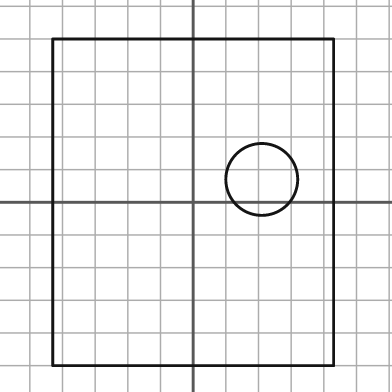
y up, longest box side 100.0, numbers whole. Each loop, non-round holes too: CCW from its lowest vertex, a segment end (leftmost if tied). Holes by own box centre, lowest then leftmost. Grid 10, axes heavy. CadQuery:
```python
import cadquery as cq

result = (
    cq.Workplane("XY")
    .moveTo(-43.0, -50.0)
    .lineTo(43.0, -50.0)
    .lineTo(43.0, 50.0)
    .lineTo(-43.0, 50.0)
    .close()
    .moveTo(21.0, 7.0)
    .circle(11.0)
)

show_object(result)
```